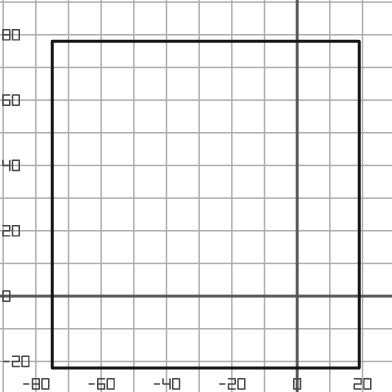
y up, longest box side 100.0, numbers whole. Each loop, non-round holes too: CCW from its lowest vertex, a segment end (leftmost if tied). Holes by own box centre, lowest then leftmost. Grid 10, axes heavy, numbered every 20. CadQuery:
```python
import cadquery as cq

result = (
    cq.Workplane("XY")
    .moveTo(-75.0, -22.0)
    .lineTo(19.0, -22.0)
    .lineTo(19.0, 78.0)
    .lineTo(-75.0, 78.0)
    .close()
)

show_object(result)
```